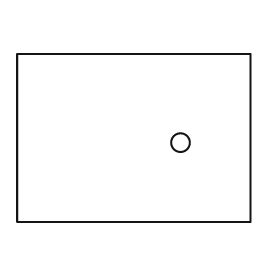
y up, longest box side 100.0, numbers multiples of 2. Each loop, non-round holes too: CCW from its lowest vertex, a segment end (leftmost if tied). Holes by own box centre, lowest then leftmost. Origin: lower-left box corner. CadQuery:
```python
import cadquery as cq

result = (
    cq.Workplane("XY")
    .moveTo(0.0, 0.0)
    .lineTo(100.0, 0.0)
    .lineTo(100.0, 72.0)
    .lineTo(0.0, 72.0)
    .close()
    .moveTo(70.0, 34.0)
    .circle(4.0)
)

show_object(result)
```